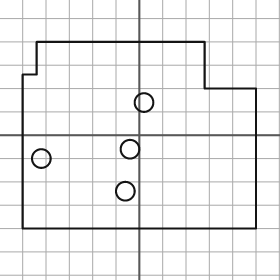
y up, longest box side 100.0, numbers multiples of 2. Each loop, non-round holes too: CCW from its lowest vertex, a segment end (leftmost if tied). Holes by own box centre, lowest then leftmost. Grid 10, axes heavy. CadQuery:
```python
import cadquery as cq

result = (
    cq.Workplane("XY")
    .moveTo(-50.0, -40.0)
    .lineTo(50.0, -40.0)
    .lineTo(50.0, 20.0)
    .lineTo(28.0, 20.0)
    .lineTo(28.0, 40.0)
    .lineTo(-44.0, 40.0)
    .lineTo(-44.0, 26.0)
    .lineTo(-50.0, 26.0)
    .close()
    .moveTo(-6.0, -24.0)
    .circle(4.0)
    .moveTo(-42.0, -10.0)
    .circle(4.0)
    .moveTo(-4.0, -6.0)
    .circle(4.0)
    .moveTo(2.0, 14.0)
    .circle(4.0)
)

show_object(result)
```